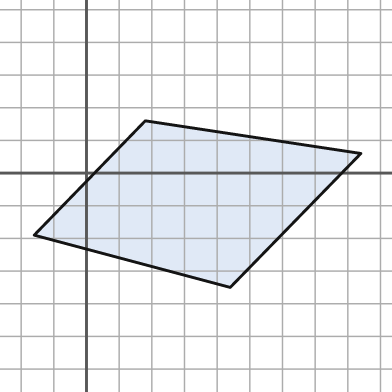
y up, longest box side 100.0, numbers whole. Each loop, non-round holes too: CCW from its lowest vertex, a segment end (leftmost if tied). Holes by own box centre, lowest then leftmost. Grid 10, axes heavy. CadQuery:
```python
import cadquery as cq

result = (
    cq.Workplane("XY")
    .moveTo(44.0, -35.0)
    .lineTo(84.0, 6.0)
    .lineTo(18.0, 16.0)
    .lineTo(-16.0, -19.0)
    .close()
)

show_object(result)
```